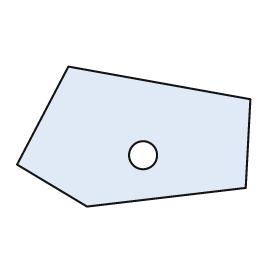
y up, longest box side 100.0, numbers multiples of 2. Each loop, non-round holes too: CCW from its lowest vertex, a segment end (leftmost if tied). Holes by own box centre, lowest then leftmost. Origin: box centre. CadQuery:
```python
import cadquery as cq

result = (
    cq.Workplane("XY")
    .moveTo(-20.0, -30.0)
    .lineTo(48.0, -22.0)
    .lineTo(50.0, 16.0)
    .lineTo(-28.0, 30.0)
    .lineTo(-50.0, -12.0)
    .close()
    .moveTo(4.0, -8.0)
    .circle(6.0)
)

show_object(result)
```